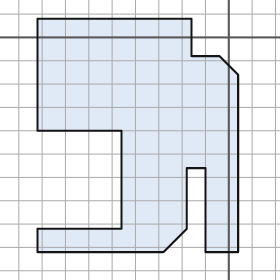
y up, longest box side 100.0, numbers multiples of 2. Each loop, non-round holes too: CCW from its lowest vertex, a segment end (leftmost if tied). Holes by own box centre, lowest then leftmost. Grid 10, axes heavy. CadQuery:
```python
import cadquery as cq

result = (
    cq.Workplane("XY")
    .moveTo(-82.0, -92.0)
    .lineTo(-28.0, -92.0)
    .lineTo(-18.0, -82.0)
    .lineTo(-18.0, -56.0)
    .lineTo(-10.0, -56.0)
    .lineTo(-10.0, -92.0)
    .lineTo(4.0, -92.0)
    .lineTo(4.0, -16.0)
    .lineTo(-4.0, -8.0)
    .lineTo(-16.0, -8.0)
    .lineTo(-16.0, 8.0)
    .lineTo(-82.0, 8.0)
    .lineTo(-82.0, -40.0)
    .lineTo(-46.0, -40.0)
    .lineTo(-46.0, -82.0)
    .lineTo(-82.0, -82.0)
    .close()
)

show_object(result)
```